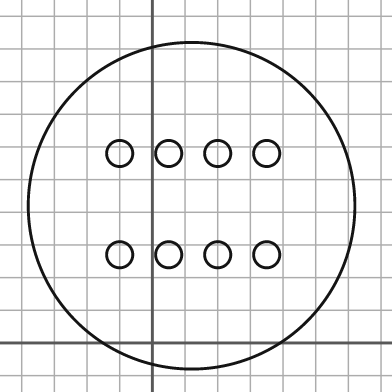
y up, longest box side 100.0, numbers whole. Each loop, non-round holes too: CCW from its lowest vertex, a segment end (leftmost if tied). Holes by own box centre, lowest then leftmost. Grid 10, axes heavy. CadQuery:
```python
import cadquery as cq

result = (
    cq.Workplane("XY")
    .moveTo(12.0, 42.0)
    .circle(50.0)
    .moveTo(-10.0, 27.0)
    .circle(4.0)
    .moveTo(5.0, 27.0)
    .circle(4.0)
    .moveTo(20.0, 27.0)
    .circle(4.0)
    .moveTo(35.0, 27.0)
    .circle(4.0)
    .moveTo(-10.0, 58.0)
    .circle(4.0)
    .moveTo(5.0, 58.0)
    .circle(4.0)
    .moveTo(20.0, 58.0)
    .circle(4.0)
    .moveTo(35.0, 58.0)
    .circle(4.0)
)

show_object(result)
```